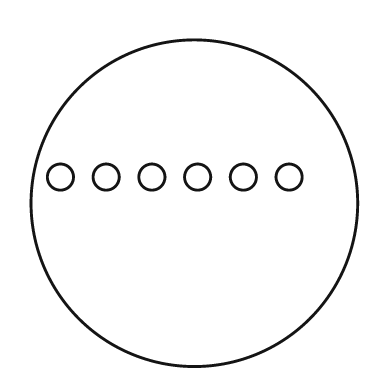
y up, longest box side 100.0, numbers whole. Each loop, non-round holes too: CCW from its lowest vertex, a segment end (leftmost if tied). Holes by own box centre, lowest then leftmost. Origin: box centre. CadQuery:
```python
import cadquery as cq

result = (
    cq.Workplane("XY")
    .moveTo(0.0, 0.0)
    .circle(50.0)
    .moveTo(-41.0, 8.0)
    .circle(4.0)
    .moveTo(-27.0, 8.0)
    .circle(4.0)
    .moveTo(-13.0, 8.0)
    .circle(4.0)
    .moveTo(1.0, 8.0)
    .circle(4.0)
    .moveTo(15.0, 8.0)
    .circle(4.0)
    .moveTo(29.0, 8.0)
    .circle(4.0)
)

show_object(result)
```